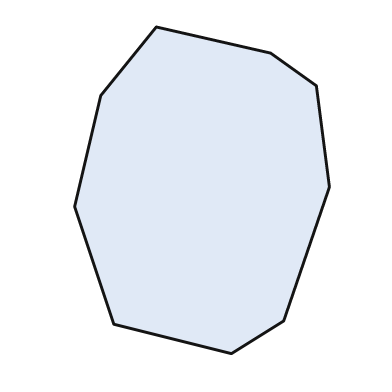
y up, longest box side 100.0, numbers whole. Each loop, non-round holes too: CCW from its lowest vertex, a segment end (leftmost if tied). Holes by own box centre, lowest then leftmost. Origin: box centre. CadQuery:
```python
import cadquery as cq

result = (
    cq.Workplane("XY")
    .moveTo(9.0, -50.0)
    .lineTo(25.0, -40.0)
    .lineTo(39.0, 1.0)
    .lineTo(35.0, 32.0)
    .lineTo(21.0, 42.0)
    .lineTo(-14.0, 50.0)
    .lineTo(-31.0, 29.0)
    .lineTo(-39.0, -5.0)
    .lineTo(-27.0, -41.0)
    .close()
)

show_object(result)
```